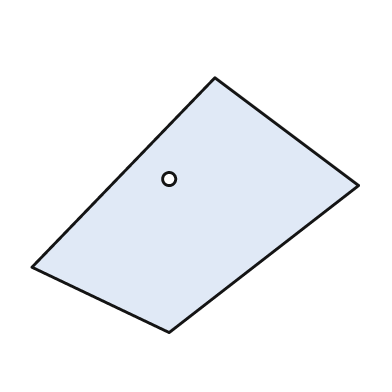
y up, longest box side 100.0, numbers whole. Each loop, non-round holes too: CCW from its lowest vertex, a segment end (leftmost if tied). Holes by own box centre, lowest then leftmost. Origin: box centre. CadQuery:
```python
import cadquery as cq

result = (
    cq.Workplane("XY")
    .moveTo(-8.0, -39.0)
    .lineTo(50.0, 6.0)
    .lineTo(6.0, 39.0)
    .lineTo(-50.0, -19.0)
    .close()
    .moveTo(-8.0, 8.0)
    .circle(2.0)
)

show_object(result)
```